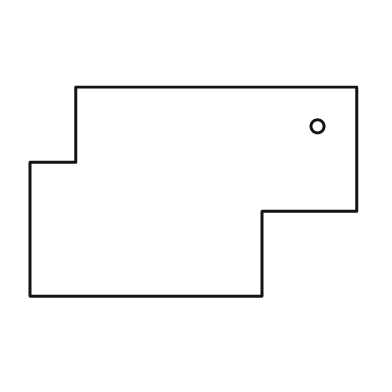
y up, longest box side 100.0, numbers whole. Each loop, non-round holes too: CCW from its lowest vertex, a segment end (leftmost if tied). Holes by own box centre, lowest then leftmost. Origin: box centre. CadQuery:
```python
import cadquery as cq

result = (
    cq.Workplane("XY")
    .moveTo(-50.0, -32.0)
    .lineTo(21.0, -32.0)
    .lineTo(21.0, -6.0)
    .lineTo(50.0, -6.0)
    .lineTo(50.0, 32.0)
    .lineTo(-36.0, 32.0)
    .lineTo(-36.0, 9.0)
    .lineTo(-50.0, 9.0)
    .close()
    .moveTo(38.0, 20.0)
    .circle(2.0)
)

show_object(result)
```